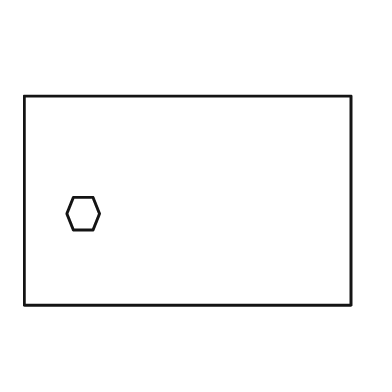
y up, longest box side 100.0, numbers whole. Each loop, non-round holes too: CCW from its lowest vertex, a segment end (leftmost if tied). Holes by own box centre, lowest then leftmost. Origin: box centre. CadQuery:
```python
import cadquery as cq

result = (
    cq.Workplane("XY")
    .moveTo(-50.0, -32.0)
    .lineTo(50.0, -32.0)
    .lineTo(50.0, 32.0)
    .lineTo(-50.0, 32.0)
    .close()
    .moveTo(-35.0, -9.0)
    .lineTo(-29.0, -9.0)
    .lineTo(-27.0, -4.0)
    .lineTo(-29.0, 1.0)
    .lineTo(-35.0, 1.0)
    .lineTo(-37.0, -4.0)
    .close()
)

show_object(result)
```